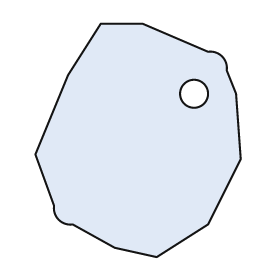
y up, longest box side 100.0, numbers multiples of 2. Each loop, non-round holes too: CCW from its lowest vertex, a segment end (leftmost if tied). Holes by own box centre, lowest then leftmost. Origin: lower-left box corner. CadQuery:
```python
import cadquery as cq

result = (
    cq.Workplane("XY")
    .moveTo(52.0, 0.0)
    .lineTo(74.0, 14.0)
    .lineTo(88.0, 42.0)
    .lineTo(86.0, 70.0)
    .lineTo(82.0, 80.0)
    .threePointArc((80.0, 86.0), (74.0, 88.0))
    .lineTo(46.0, 100.0)
    .lineTo(28.0, 100.0)
    .lineTo(14.0, 78.0)
    .lineTo(0.0, 44.0)
    .lineTo(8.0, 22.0)
    .threePointArc((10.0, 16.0), (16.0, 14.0))
    .lineTo(34.0, 4.0)
    .close()
    .moveTo(68.0, 70.0)
    .circle(6.0)
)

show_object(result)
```